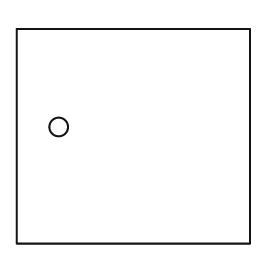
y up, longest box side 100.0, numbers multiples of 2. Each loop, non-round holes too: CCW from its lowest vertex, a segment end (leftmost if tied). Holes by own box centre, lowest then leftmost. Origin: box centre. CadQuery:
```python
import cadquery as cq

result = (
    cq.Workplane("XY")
    .moveTo(-50.0, -46.0)
    .lineTo(50.0, -46.0)
    .lineTo(50.0, 46.0)
    .lineTo(-50.0, 46.0)
    .close()
    .moveTo(-32.0, 4.0)
    .circle(4.0)
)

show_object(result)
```